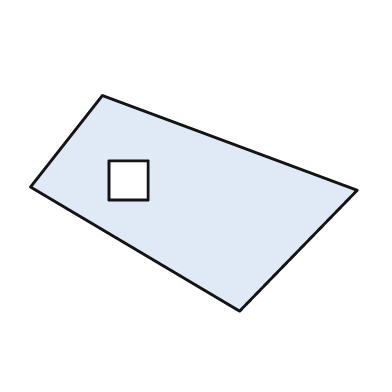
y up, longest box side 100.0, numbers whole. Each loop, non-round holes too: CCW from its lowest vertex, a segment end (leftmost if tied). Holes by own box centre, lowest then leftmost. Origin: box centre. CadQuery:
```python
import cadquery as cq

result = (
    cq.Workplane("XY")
    .moveTo(14.0, -33.0)
    .lineTo(50.0, 4.0)
    .lineTo(-28.0, 33.0)
    .lineTo(-50.0, 5.0)
    .close()
    .moveTo(-26.0, 1.0)
    .lineTo(-14.0, 1.0)
    .lineTo(-14.0, 13.0)
    .lineTo(-26.0, 13.0)
    .close()
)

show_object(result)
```